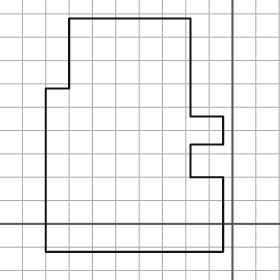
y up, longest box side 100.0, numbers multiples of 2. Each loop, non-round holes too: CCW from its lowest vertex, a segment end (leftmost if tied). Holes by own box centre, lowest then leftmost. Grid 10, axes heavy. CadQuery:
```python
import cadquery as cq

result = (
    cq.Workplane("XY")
    .moveTo(-80.0, -12.0)
    .lineTo(-4.0, -12.0)
    .lineTo(-4.0, 20.0)
    .lineTo(-18.0, 20.0)
    .lineTo(-18.0, 34.0)
    .lineTo(-4.0, 34.0)
    .lineTo(-4.0, 46.0)
    .lineTo(-18.0, 46.0)
    .lineTo(-18.0, 88.0)
    .lineTo(-70.0, 88.0)
    .lineTo(-70.0, 58.0)
    .lineTo(-80.0, 58.0)
    .close()
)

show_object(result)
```